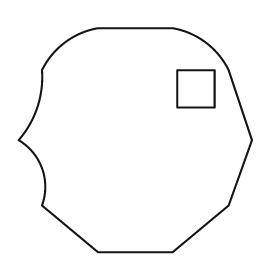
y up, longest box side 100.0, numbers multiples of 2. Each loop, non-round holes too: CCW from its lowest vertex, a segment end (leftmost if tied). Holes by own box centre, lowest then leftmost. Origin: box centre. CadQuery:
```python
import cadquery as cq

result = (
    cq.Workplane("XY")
    .moveTo(-16.0, -48.0)
    .lineTo(16.0, -48.0)
    .lineTo(40.0, -28.0)
    .lineTo(50.0, 0.0)
    .lineTo(40.0, 30.0)
    .threePointArc((30.0, 42.0), (16.0, 48.0))
    .lineTo(-16.0, 48.0)
    .threePointArc((-30.0, 42.0), (-40.0, 30.0))
    .threePointArc((-42.0, 14.0), (-50.0, 0.0))
    .threePointArc((-40.0, -12.0), (-40.0, -28.0))
    .close()
    .moveTo(18.0, 14.0)
    .lineTo(34.0, 14.0)
    .lineTo(34.0, 30.0)
    .lineTo(18.0, 30.0)
    .close()
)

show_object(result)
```